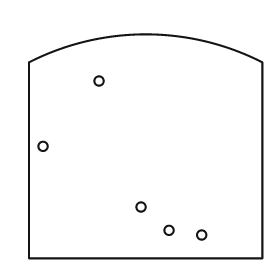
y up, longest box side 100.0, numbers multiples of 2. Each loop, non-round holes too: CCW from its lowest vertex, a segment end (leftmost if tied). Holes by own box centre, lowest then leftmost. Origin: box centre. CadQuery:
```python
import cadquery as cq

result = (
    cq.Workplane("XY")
    .moveTo(-50.0, -48.0)
    .lineTo(50.0, -48.0)
    .lineTo(50.0, 36.0)
    .threePointArc((0.0, 48.0), (-50.0, 36.0))
    .close()
    .moveTo(24.0, -38.0)
    .circle(2.0)
    .moveTo(10.0, -36.0)
    .circle(2.0)
    .moveTo(-2.0, -26.0)
    .circle(2.0)
    .moveTo(-44.0, 0.0)
    .circle(2.0)
    .moveTo(-20.0, 28.0)
    .circle(2.0)
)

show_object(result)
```